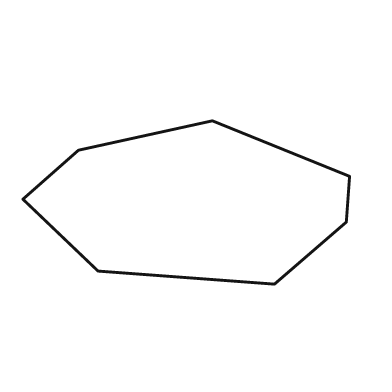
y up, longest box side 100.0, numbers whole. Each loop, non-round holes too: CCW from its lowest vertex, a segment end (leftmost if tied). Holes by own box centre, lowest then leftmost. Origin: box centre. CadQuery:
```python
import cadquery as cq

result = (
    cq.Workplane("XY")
    .moveTo(27.0, -25.0)
    .lineTo(49.0, -6.0)
    .lineTo(50.0, 8.0)
    .lineTo(8.0, 25.0)
    .lineTo(-33.0, 16.0)
    .lineTo(-50.0, 1.0)
    .lineTo(-27.0, -21.0)
    .close()
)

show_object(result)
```